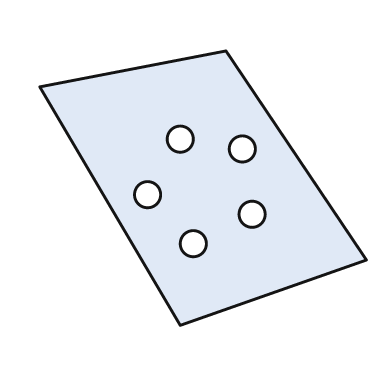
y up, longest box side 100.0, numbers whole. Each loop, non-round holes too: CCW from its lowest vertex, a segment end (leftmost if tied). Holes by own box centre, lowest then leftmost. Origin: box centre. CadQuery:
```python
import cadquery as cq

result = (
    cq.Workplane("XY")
    .moveTo(-7.0, -42.0)
    .lineTo(50.0, -22.0)
    .lineTo(7.0, 42.0)
    .lineTo(-50.0, 31.0)
    .close()
    .moveTo(-3.0, -17.0)
    .circle(4.0)
    .moveTo(15.0, -8.0)
    .circle(4.0)
    .moveTo(-17.0, -2.0)
    .circle(4.0)
    .moveTo(12.0, 12.0)
    .circle(4.0)
    .moveTo(-7.0, 15.0)
    .circle(4.0)
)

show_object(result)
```